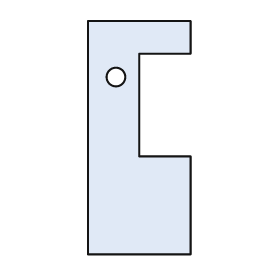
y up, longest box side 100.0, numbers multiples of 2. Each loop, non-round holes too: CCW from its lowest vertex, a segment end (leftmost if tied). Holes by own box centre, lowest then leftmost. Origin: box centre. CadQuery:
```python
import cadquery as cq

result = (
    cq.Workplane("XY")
    .moveTo(-22.0, -50.0)
    .lineTo(22.0, -50.0)
    .lineTo(22.0, -8.0)
    .lineTo(0.0, -8.0)
    .lineTo(0.0, 36.0)
    .lineTo(22.0, 36.0)
    .lineTo(22.0, 50.0)
    .lineTo(-22.0, 50.0)
    .close()
    .moveTo(-10.0, 26.0)
    .circle(4.0)
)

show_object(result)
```